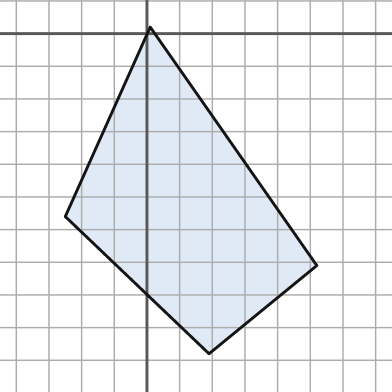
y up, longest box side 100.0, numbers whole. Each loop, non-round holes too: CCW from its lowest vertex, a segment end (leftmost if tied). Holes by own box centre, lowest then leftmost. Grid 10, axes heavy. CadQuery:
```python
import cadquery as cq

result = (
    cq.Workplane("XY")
    .moveTo(19.0, -98.0)
    .lineTo(52.0, -71.0)
    .lineTo(1.0, 2.0)
    .lineTo(-25.0, -56.0)
    .close()
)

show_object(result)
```